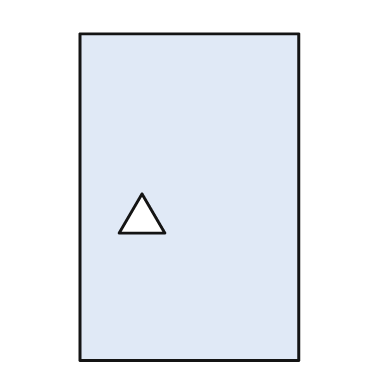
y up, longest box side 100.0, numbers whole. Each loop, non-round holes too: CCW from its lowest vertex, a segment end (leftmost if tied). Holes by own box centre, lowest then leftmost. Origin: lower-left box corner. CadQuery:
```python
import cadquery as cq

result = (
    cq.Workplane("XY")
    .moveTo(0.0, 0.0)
    .lineTo(67.0, 0.0)
    .lineTo(67.0, 100.0)
    .lineTo(0.0, 100.0)
    .close()
    .moveTo(12.0, 39.0)
    .lineTo(26.0, 39.0)
    .lineTo(19.0, 51.0)
    .close()
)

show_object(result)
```